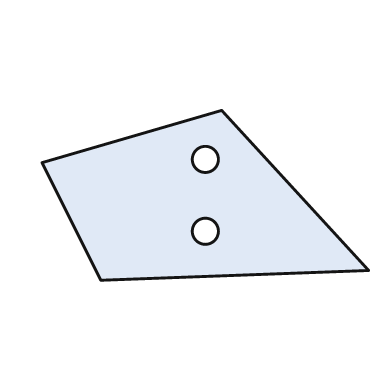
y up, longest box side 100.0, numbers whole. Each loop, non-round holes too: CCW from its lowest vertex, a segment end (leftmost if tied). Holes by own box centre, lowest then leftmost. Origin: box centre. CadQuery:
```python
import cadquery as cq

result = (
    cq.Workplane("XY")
    .moveTo(-32.0, -26.0)
    .lineTo(50.0, -23.0)
    .lineTo(5.0, 26.0)
    .lineTo(-50.0, 10.0)
    .close()
    .moveTo(0.0, -11.0)
    .circle(4.0)
    .moveTo(0.0, 11.0)
    .circle(4.0)
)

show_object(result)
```